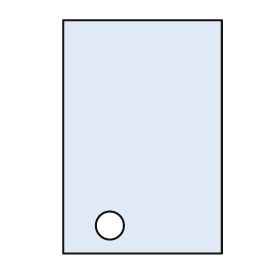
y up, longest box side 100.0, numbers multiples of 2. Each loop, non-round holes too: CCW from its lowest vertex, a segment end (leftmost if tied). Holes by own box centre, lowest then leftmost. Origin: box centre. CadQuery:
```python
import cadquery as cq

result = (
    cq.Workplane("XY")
    .moveTo(-34.0, -50.0)
    .lineTo(34.0, -50.0)
    .lineTo(34.0, 50.0)
    .lineTo(-34.0, 50.0)
    .close()
    .moveTo(-14.0, -38.0)
    .circle(6.0)
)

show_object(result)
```